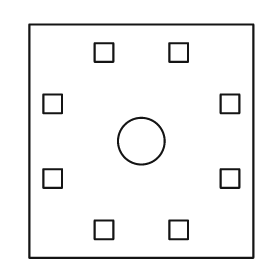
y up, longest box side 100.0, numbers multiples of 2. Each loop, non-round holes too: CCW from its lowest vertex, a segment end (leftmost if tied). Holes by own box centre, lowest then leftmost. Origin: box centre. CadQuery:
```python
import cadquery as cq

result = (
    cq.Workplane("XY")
    .moveTo(-48.0, -50.0)
    .lineTo(48.0, -50.0)
    .lineTo(48.0, 50.0)
    .lineTo(-48.0, 50.0)
    .close()
    .moveTo(-20.0, -42.0)
    .lineTo(-12.0, -42.0)
    .lineTo(-12.0, -34.0)
    .lineTo(-20.0, -34.0)
    .close()
    .moveTo(12.0, -42.0)
    .lineTo(20.0, -42.0)
    .lineTo(20.0, -34.0)
    .lineTo(12.0, -34.0)
    .close()
    .moveTo(-42.0, -20.0)
    .lineTo(-34.0, -20.0)
    .lineTo(-34.0, -12.0)
    .lineTo(-42.0, -12.0)
    .close()
    .moveTo(34.0, -20.0)
    .lineTo(42.0, -20.0)
    .lineTo(42.0, -12.0)
    .lineTo(34.0, -12.0)
    .close()
    .moveTo(0.0, 0.0)
    .circle(10.0)
    .moveTo(-42.0, 12.0)
    .lineTo(-34.0, 12.0)
    .lineTo(-34.0, 20.0)
    .lineTo(-42.0, 20.0)
    .close()
    .moveTo(34.0, 12.0)
    .lineTo(42.0, 12.0)
    .lineTo(42.0, 20.0)
    .lineTo(34.0, 20.0)
    .close()
    .moveTo(-20.0, 34.0)
    .lineTo(-12.0, 34.0)
    .lineTo(-12.0, 42.0)
    .lineTo(-20.0, 42.0)
    .close()
    .moveTo(12.0, 34.0)
    .lineTo(20.0, 34.0)
    .lineTo(20.0, 42.0)
    .lineTo(12.0, 42.0)
    .close()
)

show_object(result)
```